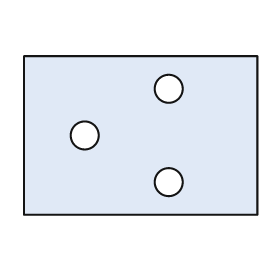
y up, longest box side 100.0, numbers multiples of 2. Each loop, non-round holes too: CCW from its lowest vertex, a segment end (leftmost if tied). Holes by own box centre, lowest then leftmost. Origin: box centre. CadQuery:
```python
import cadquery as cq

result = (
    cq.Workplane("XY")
    .moveTo(-50.0, -34.0)
    .lineTo(50.0, -34.0)
    .lineTo(50.0, 34.0)
    .lineTo(-50.0, 34.0)
    .close()
    .moveTo(12.0, -20.0)
    .circle(6.0)
    .moveTo(-24.0, 0.0)
    .circle(6.0)
    .moveTo(12.0, 20.0)
    .circle(6.0)
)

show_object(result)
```